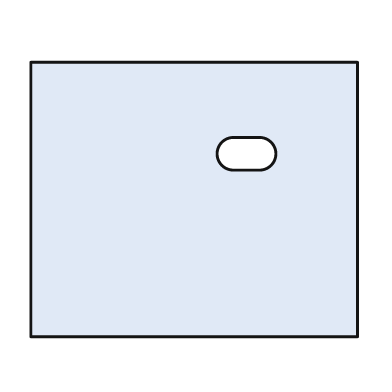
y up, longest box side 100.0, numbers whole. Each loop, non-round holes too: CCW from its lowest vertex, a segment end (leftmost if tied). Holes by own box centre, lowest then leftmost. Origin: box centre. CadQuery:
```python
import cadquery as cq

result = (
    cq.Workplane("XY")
    .moveTo(-50.0, -42.0)
    .lineTo(50.0, -42.0)
    .lineTo(50.0, 42.0)
    .lineTo(-50.0, 42.0)
    .close()
    .moveTo(12.0, 9.0)
    .lineTo(20.0, 9.0)
    .threePointArc((25.0, 14.0), (20.0, 19.0))
    .lineTo(12.0, 19.0)
    .threePointArc((7.0, 14.0), (12.0, 9.0))
    .close()
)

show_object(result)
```